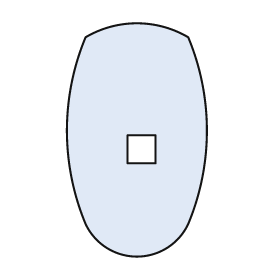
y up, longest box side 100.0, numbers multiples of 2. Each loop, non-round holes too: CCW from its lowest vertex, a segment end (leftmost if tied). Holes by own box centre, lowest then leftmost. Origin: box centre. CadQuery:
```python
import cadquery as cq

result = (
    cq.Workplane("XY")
    .moveTo(-22.0, -36.0)
    .threePointArc((0.0, -50.0), (22.0, -36.0))
    .threePointArc((30.0, 4.0), (22.0, 44.0))
    .threePointArc((0.0, 50.0), (-22.0, 44.0))
    .threePointArc((-30.0, 4.0), (-22.0, -36.0))
    .close()
    .moveTo(-4.0, -10.0)
    .lineTo(8.0, -10.0)
    .lineTo(8.0, 2.0)
    .lineTo(-4.0, 2.0)
    .close()
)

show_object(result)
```